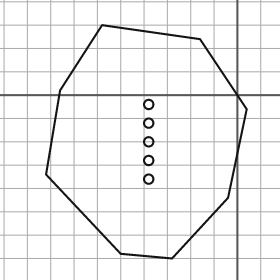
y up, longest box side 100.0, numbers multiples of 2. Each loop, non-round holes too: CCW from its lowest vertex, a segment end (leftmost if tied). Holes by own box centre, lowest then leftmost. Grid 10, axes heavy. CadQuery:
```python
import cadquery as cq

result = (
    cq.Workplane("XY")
    .moveTo(-28.0, -70.0)
    .lineTo(-4.0, -44.0)
    .lineTo(4.0, -6.0)
    .lineTo(-16.0, 24.0)
    .lineTo(-58.0, 30.0)
    .lineTo(-76.0, 2.0)
    .lineTo(-82.0, -34.0)
    .lineTo(-50.0, -68.0)
    .close()
    .moveTo(-38.0, -36.0)
    .circle(2.0)
    .moveTo(-38.0, -28.0)
    .circle(2.0)
    .moveTo(-38.0, -20.0)
    .circle(2.0)
    .moveTo(-38.0, -12.0)
    .circle(2.0)
    .moveTo(-38.0, -4.0)
    .circle(2.0)
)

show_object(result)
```